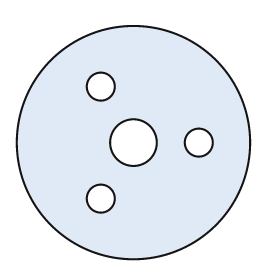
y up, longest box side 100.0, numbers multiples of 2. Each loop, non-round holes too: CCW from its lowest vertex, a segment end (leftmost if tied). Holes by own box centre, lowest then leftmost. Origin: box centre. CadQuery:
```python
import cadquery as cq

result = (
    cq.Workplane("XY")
    .moveTo(0.0, 0.0)
    .circle(50.0)
    .moveTo(-14.0, -24.0)
    .circle(6.0)
    .moveTo(0.0, 0.0)
    .circle(10.0)
    .moveTo(28.0, 0.0)
    .circle(6.0)
    .moveTo(-14.0, 24.0)
    .circle(6.0)
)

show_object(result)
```